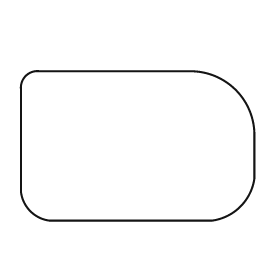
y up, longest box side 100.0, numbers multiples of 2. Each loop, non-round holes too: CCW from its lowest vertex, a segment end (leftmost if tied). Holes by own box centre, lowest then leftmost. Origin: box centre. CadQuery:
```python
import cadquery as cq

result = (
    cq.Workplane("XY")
    .moveTo(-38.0, -32.0)
    .lineTo(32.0, -32.0)
    .threePointArc((44.0, -26.0), (50.0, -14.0))
    .lineTo(50.0, 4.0)
    .threePointArc((42.0, 24.0), (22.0, 32.0))
    .lineTo(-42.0, 32.0)
    .threePointArc((-48.0, 30.0), (-50.0, 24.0))
    .lineTo(-50.0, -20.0)
    .threePointArc((-46.0, -28.0), (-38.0, -32.0))
    .close()
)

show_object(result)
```